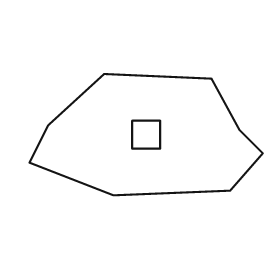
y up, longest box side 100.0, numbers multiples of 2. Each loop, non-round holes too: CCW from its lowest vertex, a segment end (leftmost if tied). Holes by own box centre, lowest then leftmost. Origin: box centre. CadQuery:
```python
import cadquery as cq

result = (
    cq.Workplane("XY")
    .moveTo(-14.0, -26.0)
    .lineTo(36.0, -24.0)
    .lineTo(50.0, -8.0)
    .lineTo(40.0, 2.0)
    .lineTo(28.0, 24.0)
    .lineTo(-18.0, 26.0)
    .lineTo(-42.0, 4.0)
    .lineTo(-50.0, -12.0)
    .close()
    .moveTo(-6.0, -6.0)
    .lineTo(6.0, -6.0)
    .lineTo(6.0, 6.0)
    .lineTo(-6.0, 6.0)
    .close()
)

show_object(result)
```